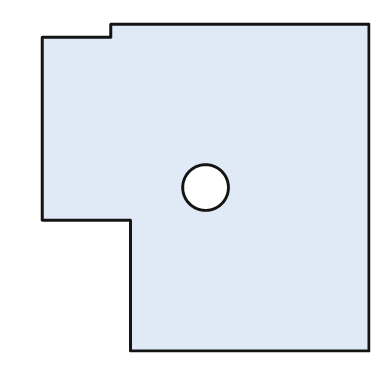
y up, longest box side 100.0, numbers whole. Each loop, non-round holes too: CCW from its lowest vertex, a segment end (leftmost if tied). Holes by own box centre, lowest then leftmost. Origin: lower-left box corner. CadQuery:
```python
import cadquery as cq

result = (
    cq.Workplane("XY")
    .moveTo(27.0, 0.0)
    .lineTo(100.0, 0.0)
    .lineTo(100.0, 100.0)
    .lineTo(21.0, 100.0)
    .lineTo(21.0, 96.0)
    .lineTo(0.0, 96.0)
    .lineTo(0.0, 40.0)
    .lineTo(27.0, 40.0)
    .close()
    .moveTo(50.0, 50.0)
    .circle(7.0)
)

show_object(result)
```